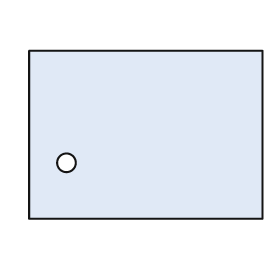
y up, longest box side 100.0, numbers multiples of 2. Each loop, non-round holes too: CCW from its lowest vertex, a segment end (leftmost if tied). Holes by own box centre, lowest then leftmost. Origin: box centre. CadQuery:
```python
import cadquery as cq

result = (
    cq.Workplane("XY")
    .moveTo(-50.0, -36.0)
    .lineTo(50.0, -36.0)
    .lineTo(50.0, 36.0)
    .lineTo(-50.0, 36.0)
    .close()
    .moveTo(-34.0, -12.0)
    .circle(4.0)
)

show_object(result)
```